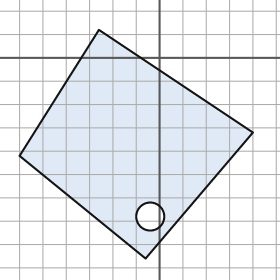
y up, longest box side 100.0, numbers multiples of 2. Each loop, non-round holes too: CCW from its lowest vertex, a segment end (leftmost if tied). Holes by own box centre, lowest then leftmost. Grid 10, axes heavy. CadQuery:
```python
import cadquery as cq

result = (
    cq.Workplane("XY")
    .moveTo(-6.0, -86.0)
    .lineTo(40.0, -32.0)
    .lineTo(-26.0, 12.0)
    .lineTo(-60.0, -42.0)
    .close()
    .moveTo(-4.0, -68.0)
    .circle(6.0)
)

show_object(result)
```